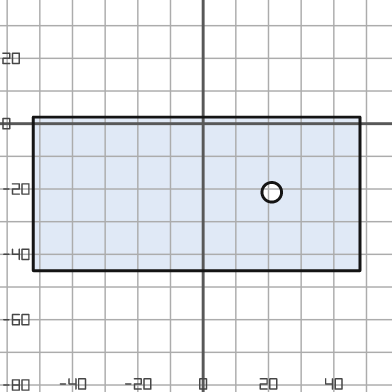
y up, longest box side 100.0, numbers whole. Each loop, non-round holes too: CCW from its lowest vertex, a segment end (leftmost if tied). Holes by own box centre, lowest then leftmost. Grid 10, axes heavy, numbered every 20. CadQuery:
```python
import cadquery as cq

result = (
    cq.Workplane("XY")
    .moveTo(-52.0, -45.0)
    .lineTo(48.0, -45.0)
    .lineTo(48.0, 2.0)
    .lineTo(-52.0, 2.0)
    .close()
    .moveTo(21.0, -21.0)
    .circle(3.0)
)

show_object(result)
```